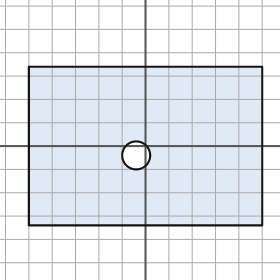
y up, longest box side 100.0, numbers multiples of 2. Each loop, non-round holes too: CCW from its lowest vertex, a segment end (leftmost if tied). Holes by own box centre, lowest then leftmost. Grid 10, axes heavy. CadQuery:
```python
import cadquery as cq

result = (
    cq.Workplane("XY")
    .moveTo(-50.0, -34.0)
    .lineTo(50.0, -34.0)
    .lineTo(50.0, 34.0)
    .lineTo(-50.0, 34.0)
    .close()
    .moveTo(-4.0, -4.0)
    .circle(6.0)
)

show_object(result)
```